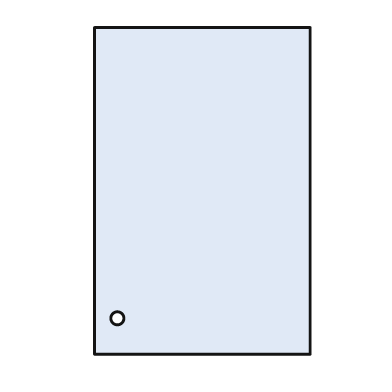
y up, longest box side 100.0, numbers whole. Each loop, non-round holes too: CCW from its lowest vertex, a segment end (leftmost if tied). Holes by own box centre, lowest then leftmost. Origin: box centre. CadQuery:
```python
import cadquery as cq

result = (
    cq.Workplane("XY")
    .moveTo(-33.0, -50.0)
    .lineTo(33.0, -50.0)
    .lineTo(33.0, 50.0)
    .lineTo(-33.0, 50.0)
    .close()
    .moveTo(-26.0, -39.0)
    .circle(2.0)
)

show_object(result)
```